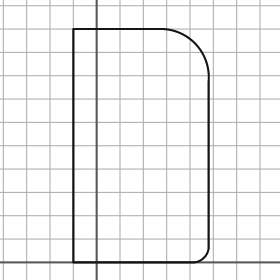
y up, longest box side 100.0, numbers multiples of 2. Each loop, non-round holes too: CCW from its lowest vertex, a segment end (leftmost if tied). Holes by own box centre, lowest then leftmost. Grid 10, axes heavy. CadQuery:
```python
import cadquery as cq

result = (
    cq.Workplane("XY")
    .moveTo(-10.0, 0.0)
    .lineTo(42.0, 0.0)
    .threePointArc((46.0, 2.0), (48.0, 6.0))
    .lineTo(48.0, 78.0)
    .threePointArc((42.0, 94.0), (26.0, 100.0))
    .lineTo(-10.0, 100.0)
    .close()
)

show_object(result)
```